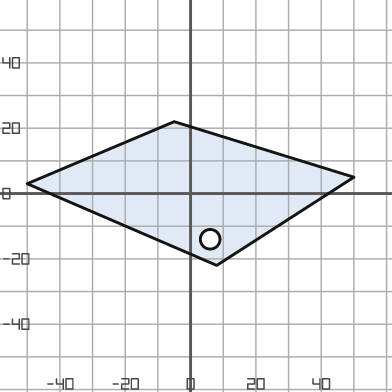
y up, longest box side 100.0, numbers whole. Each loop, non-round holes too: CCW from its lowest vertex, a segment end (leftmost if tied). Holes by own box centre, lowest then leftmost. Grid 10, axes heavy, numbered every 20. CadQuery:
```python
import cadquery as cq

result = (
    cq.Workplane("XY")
    .moveTo(8.0, -22.0)
    .lineTo(50.0, 5.0)
    .lineTo(-5.0, 22.0)
    .lineTo(-50.0, 3.0)
    .close()
    .moveTo(6.0, -14.0)
    .circle(3.0)
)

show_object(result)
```